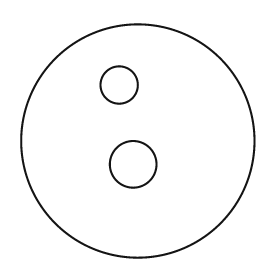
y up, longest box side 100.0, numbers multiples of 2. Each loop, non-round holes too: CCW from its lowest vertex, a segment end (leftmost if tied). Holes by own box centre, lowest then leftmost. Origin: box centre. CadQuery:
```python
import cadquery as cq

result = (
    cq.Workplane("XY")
    .moveTo(0.0, 0.0)
    .circle(50.0)
    .moveTo(-2.0, -10.0)
    .circle(10.0)
    .moveTo(-8.0, 24.0)
    .circle(8.0)
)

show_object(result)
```